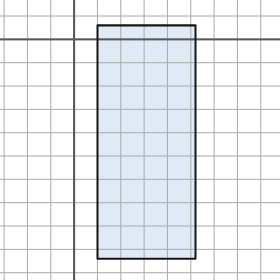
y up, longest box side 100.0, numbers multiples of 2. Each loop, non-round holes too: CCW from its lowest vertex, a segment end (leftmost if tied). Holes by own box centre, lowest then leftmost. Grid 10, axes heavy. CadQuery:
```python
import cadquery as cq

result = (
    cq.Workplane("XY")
    .moveTo(10.0, -94.0)
    .lineTo(52.0, -94.0)
    .lineTo(52.0, 6.0)
    .lineTo(10.0, 6.0)
    .close()
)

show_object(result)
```